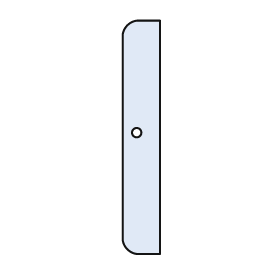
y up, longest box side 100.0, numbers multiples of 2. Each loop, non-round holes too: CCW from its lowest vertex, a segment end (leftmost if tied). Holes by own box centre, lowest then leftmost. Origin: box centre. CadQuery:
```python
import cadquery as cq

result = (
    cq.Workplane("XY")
    .moveTo(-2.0, -50.0)
    .lineTo(8.0, -50.0)
    .lineTo(8.0, 50.0)
    .lineTo(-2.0, 50.0)
    .threePointArc((-6.0, 48.0), (-8.0, 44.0))
    .lineTo(-8.0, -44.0)
    .threePointArc((-6.0, -48.0), (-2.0, -50.0))
    .close()
    .moveTo(-2.0, 2.0)
    .circle(2.0)
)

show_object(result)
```